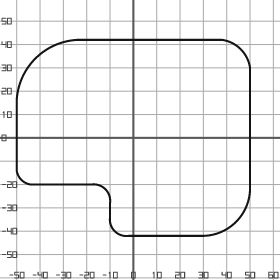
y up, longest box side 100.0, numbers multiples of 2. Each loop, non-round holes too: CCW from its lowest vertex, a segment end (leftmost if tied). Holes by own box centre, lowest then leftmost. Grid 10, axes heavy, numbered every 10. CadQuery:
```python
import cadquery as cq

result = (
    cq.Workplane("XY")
    .moveTo(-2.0, -42.0)
    .lineTo(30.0, -42.0)
    .threePointArc((44.0, -36.0), (50.0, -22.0))
    .lineTo(50.0, 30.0)
    .threePointArc((46.0, 38.0), (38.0, 42.0))
    .lineTo(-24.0, 42.0)
    .threePointArc((-42.0, 34.0), (-50.0, 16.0))
    .lineTo(-50.0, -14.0)
    .threePointArc((-48.0, -18.0), (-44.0, -20.0))
    .lineTo(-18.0, -20.0)
    .threePointArc((-12.0, -22.0), (-10.0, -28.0))
    .lineTo(-10.0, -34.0)
    .threePointArc((-8.0, -40.0), (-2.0, -42.0))
    .close()
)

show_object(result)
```